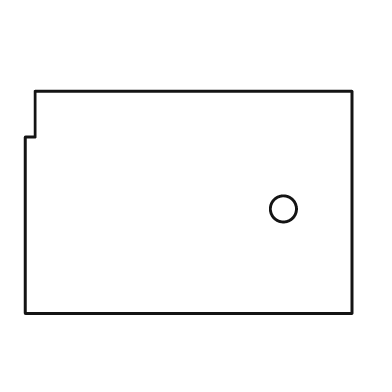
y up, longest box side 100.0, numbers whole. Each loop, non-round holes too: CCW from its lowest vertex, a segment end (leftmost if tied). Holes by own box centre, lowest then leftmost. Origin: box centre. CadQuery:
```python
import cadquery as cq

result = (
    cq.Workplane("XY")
    .moveTo(-50.0, -34.0)
    .lineTo(50.0, -34.0)
    .lineTo(50.0, 34.0)
    .lineTo(-47.0, 34.0)
    .lineTo(-47.0, 20.0)
    .lineTo(-50.0, 20.0)
    .close()
    .moveTo(29.0, -2.0)
    .circle(4.0)
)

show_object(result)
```